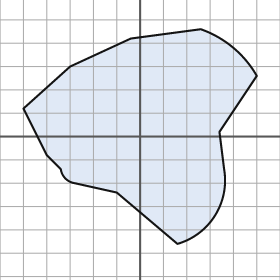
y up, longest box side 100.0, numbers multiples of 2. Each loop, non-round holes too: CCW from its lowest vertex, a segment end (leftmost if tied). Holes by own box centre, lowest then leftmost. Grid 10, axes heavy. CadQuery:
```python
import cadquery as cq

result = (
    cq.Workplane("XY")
    .moveTo(16.0, -46.0)
    .threePointArc((32.0, -34.0), (36.0, -14.0))
    .lineTo(34.0, 2.0)
    .lineTo(50.0, 26.0)
    .threePointArc((40.0, 38.0), (26.0, 46.0))
    .lineTo(-4.0, 42.0)
    .lineTo(-30.0, 30.0)
    .lineTo(-50.0, 12.0)
    .lineTo(-40.0, -8.0)
    .lineTo(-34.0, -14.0)
    .threePointArc((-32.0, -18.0), (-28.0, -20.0))
    .lineTo(-10.0, -24.0)
    .close()
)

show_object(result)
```